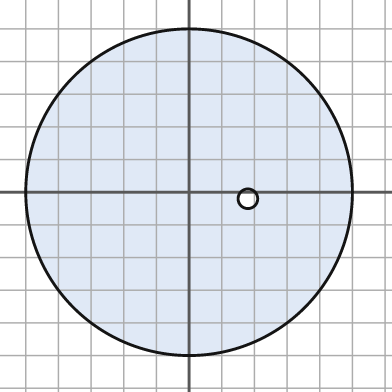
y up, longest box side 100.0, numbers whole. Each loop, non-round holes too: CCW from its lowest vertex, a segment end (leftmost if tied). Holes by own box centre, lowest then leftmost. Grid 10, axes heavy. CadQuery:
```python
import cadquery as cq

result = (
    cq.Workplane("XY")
    .moveTo(0.0, 0.0)
    .circle(50.0)
    .moveTo(18.0, -2.0)
    .circle(3.0)
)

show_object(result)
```